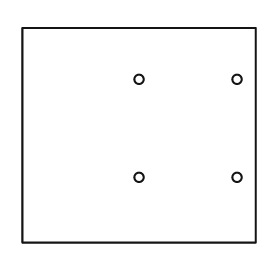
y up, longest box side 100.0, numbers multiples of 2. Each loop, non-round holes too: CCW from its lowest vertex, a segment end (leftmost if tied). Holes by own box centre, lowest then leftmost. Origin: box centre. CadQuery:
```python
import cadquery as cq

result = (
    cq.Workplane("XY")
    .moveTo(-50.0, -46.0)
    .lineTo(50.0, -46.0)
    .lineTo(50.0, 46.0)
    .lineTo(-50.0, 46.0)
    .close()
    .moveTo(0.0, -18.0)
    .circle(2.0)
    .moveTo(42.0, -18.0)
    .circle(2.0)
    .moveTo(0.0, 24.0)
    .circle(2.0)
    .moveTo(42.0, 24.0)
    .circle(2.0)
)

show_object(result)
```